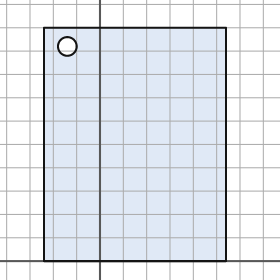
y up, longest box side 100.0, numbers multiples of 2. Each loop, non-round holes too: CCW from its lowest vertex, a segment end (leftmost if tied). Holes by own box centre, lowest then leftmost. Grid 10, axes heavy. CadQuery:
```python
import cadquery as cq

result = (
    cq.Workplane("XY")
    .moveTo(-24.0, 0.0)
    .lineTo(54.0, 0.0)
    .lineTo(54.0, 100.0)
    .lineTo(-24.0, 100.0)
    .close()
    .moveTo(-14.0, 92.0)
    .circle(4.0)
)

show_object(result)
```